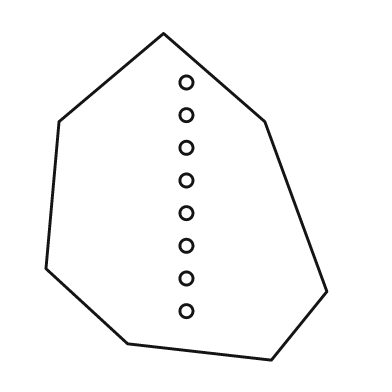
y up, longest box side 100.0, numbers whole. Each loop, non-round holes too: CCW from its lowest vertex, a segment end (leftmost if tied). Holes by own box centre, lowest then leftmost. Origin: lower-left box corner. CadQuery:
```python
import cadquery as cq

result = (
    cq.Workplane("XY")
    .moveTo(69.0, 0.0)
    .lineTo(86.0, 21.0)
    .lineTo(67.0, 73.0)
    .lineTo(36.0, 100.0)
    .lineTo(4.0, 73.0)
    .lineTo(0.0, 28.0)
    .lineTo(25.0, 5.0)
    .close()
    .moveTo(43.0, 15.0)
    .circle(2.0)
    .moveTo(43.0, 25.0)
    .circle(2.0)
    .moveTo(43.0, 35.0)
    .circle(2.0)
    .moveTo(43.0, 45.0)
    .circle(2.0)
    .moveTo(43.0, 55.0)
    .circle(2.0)
    .moveTo(43.0, 65.0)
    .circle(2.0)
    .moveTo(43.0, 75.0)
    .circle(2.0)
    .moveTo(43.0, 85.0)
    .circle(2.0)
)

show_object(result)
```